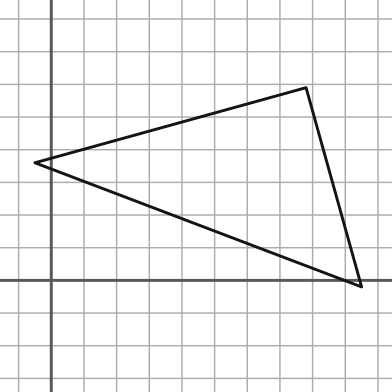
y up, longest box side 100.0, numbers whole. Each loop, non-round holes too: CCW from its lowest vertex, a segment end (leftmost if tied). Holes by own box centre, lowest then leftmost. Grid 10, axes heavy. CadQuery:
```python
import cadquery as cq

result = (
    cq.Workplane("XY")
    .moveTo(95.0, -2.0)
    .lineTo(78.0, 59.0)
    .lineTo(-5.0, 36.0)
    .close()
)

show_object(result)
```